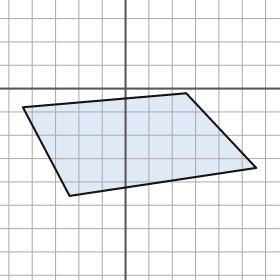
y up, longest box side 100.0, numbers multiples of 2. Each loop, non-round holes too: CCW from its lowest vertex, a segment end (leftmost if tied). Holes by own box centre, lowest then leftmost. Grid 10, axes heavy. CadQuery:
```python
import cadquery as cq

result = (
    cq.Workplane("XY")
    .moveTo(-24.0, -46.0)
    .lineTo(56.0, -34.0)
    .lineTo(26.0, -2.0)
    .lineTo(-44.0, -8.0)
    .close()
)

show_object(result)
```